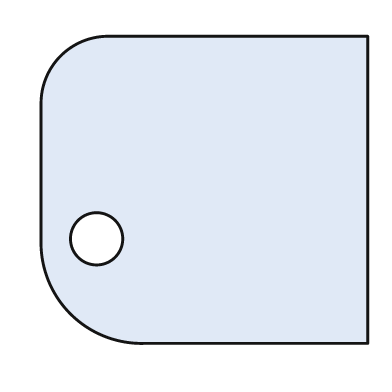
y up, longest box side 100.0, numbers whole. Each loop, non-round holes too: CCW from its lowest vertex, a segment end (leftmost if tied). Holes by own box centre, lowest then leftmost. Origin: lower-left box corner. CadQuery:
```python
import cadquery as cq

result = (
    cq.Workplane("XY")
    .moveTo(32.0, 0.0)
    .lineTo(100.0, 0.0)
    .lineTo(100.0, 94.0)
    .lineTo(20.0, 94.0)
    .threePointArc((6.0, 88.0), (0.0, 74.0))
    .lineTo(0.0, 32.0)
    .threePointArc((9.0, 9.0), (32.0, 0.0))
    .close()
    .moveTo(17.0, 32.0)
    .circle(8.0)
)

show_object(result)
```